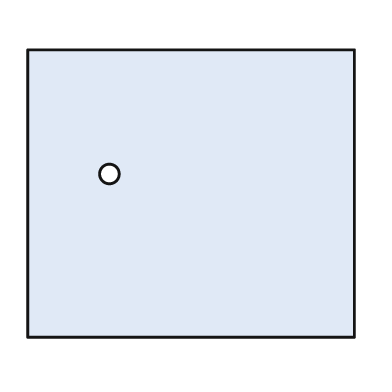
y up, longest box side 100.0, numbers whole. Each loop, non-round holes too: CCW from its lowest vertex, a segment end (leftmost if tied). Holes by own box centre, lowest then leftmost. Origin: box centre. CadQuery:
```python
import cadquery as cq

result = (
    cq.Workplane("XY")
    .moveTo(-50.0, -44.0)
    .lineTo(50.0, -44.0)
    .lineTo(50.0, 44.0)
    .lineTo(-50.0, 44.0)
    .close()
    .moveTo(-25.0, 6.0)
    .circle(3.0)
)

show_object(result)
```